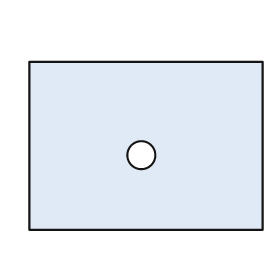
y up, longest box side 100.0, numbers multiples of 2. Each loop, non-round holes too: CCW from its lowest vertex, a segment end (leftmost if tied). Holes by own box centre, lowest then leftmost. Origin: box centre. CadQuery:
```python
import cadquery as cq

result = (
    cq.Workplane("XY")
    .moveTo(-50.0, -36.0)
    .lineTo(50.0, -36.0)
    .lineTo(50.0, 36.0)
    .lineTo(-50.0, 36.0)
    .close()
    .moveTo(-2.0, -4.0)
    .circle(6.0)
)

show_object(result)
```